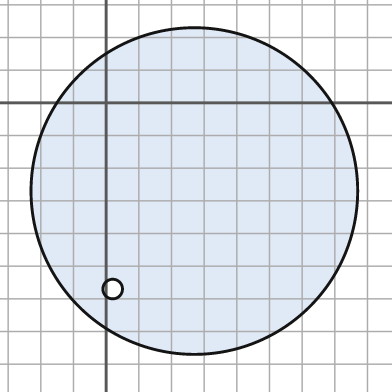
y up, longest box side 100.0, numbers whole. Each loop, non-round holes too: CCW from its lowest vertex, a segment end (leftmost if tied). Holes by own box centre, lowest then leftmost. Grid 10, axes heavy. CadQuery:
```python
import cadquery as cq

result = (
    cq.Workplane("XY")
    .moveTo(27.0, -27.0)
    .circle(50.0)
    .moveTo(2.0, -57.0)
    .circle(3.0)
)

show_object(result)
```